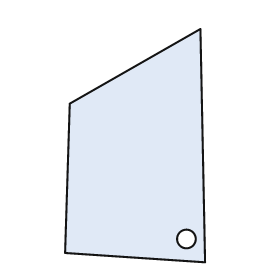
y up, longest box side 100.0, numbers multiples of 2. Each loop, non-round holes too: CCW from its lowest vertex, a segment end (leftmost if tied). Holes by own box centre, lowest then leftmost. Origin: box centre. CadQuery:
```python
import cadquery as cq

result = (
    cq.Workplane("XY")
    .moveTo(30.0, -50.0)
    .lineTo(28.0, 50.0)
    .lineTo(-28.0, 18.0)
    .lineTo(-30.0, -46.0)
    .close()
    .moveTo(22.0, -40.0)
    .circle(4.0)
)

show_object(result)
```